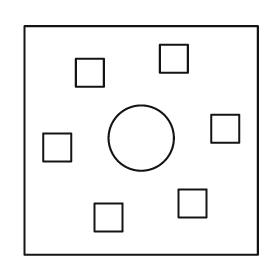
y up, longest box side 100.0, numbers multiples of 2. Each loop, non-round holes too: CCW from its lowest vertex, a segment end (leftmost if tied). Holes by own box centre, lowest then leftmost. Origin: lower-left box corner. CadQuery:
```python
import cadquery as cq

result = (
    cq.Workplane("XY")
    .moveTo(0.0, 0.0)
    .lineTo(100.0, 0.0)
    .lineTo(100.0, 98.0)
    .lineTo(0.0, 98.0)
    .close()
    .moveTo(30.0, 10.0)
    .lineTo(42.0, 10.0)
    .lineTo(42.0, 22.0)
    .lineTo(30.0, 22.0)
    .close()
    .moveTo(66.0, 16.0)
    .lineTo(78.0, 16.0)
    .lineTo(78.0, 28.0)
    .lineTo(66.0, 28.0)
    .close()
    .moveTo(8.0, 40.0)
    .lineTo(20.0, 40.0)
    .lineTo(20.0, 52.0)
    .lineTo(8.0, 52.0)
    .close()
    .moveTo(50.0, 50.0)
    .circle(14.0)
    .moveTo(80.0, 48.0)
    .lineTo(92.0, 48.0)
    .lineTo(92.0, 60.0)
    .lineTo(80.0, 60.0)
    .close()
    .moveTo(22.0, 72.0)
    .lineTo(34.0, 72.0)
    .lineTo(34.0, 84.0)
    .lineTo(22.0, 84.0)
    .close()
    .moveTo(58.0, 78.0)
    .lineTo(70.0, 78.0)
    .lineTo(70.0, 90.0)
    .lineTo(58.0, 90.0)
    .close()
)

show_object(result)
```